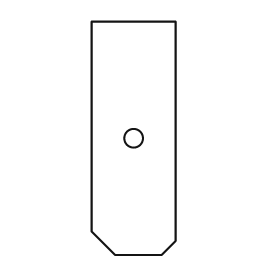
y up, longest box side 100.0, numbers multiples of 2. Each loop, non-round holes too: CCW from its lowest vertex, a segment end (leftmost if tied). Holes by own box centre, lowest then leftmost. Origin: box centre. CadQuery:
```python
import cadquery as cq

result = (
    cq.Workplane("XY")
    .moveTo(-8.0, -50.0)
    .lineTo(12.0, -50.0)
    .lineTo(18.0, -44.0)
    .lineTo(18.0, 50.0)
    .lineTo(-18.0, 50.0)
    .lineTo(-18.0, -40.0)
    .close()
    .moveTo(0.0, 0.0)
    .circle(4.0)
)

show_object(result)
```